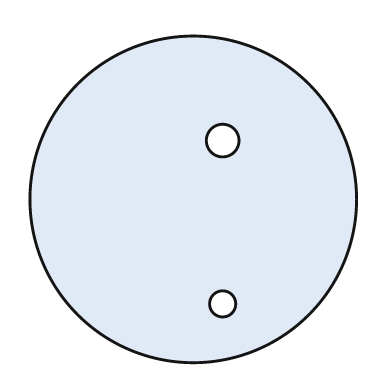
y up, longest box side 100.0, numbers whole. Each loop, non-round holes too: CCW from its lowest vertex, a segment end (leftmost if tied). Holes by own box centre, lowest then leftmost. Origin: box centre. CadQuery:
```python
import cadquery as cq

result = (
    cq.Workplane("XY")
    .moveTo(0.0, 0.0)
    .circle(50.0)
    .moveTo(9.0, -32.0)
    .circle(4.0)
    .moveTo(9.0, 18.0)
    .circle(5.0)
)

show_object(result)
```